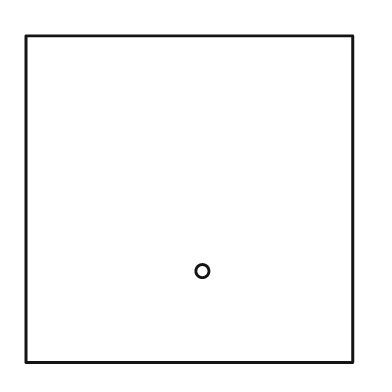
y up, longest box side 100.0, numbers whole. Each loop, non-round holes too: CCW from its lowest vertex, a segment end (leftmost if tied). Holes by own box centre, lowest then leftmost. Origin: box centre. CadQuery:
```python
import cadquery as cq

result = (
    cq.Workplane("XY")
    .moveTo(-50.0, -50.0)
    .lineTo(50.0, -50.0)
    .lineTo(50.0, 50.0)
    .lineTo(-50.0, 50.0)
    .close()
    .moveTo(4.0, -22.0)
    .circle(2.0)
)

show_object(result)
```